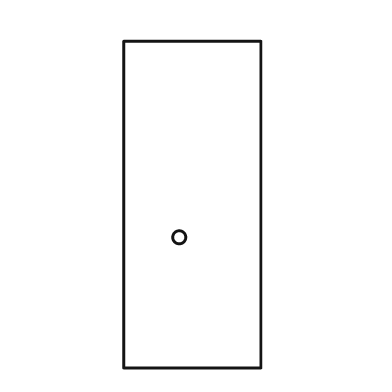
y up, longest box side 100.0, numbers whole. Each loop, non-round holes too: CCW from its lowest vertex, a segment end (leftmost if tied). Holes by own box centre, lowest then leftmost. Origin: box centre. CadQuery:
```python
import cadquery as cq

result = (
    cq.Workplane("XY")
    .moveTo(-21.0, -50.0)
    .lineTo(21.0, -50.0)
    .lineTo(21.0, 50.0)
    .lineTo(-21.0, 50.0)
    .close()
    .moveTo(-4.0, -10.0)
    .circle(2.0)
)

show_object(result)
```